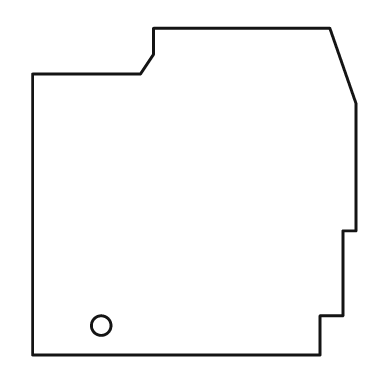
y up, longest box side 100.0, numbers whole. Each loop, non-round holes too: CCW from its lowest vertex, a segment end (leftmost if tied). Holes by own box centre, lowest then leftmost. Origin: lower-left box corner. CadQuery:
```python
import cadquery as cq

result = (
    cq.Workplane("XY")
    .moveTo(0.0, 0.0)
    .lineTo(88.0, 0.0)
    .lineTo(88.0, 12.0)
    .lineTo(95.0, 12.0)
    .lineTo(95.0, 38.0)
    .lineTo(99.0, 38.0)
    .lineTo(99.0, 77.0)
    .lineTo(91.0, 100.0)
    .lineTo(37.0, 100.0)
    .lineTo(37.0, 92.0)
    .lineTo(33.0, 86.0)
    .lineTo(0.0, 86.0)
    .close()
    .moveTo(21.0, 9.0)
    .circle(3.0)
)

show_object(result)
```